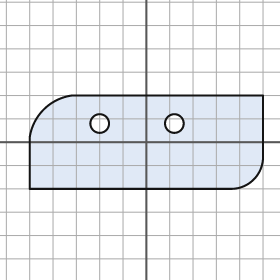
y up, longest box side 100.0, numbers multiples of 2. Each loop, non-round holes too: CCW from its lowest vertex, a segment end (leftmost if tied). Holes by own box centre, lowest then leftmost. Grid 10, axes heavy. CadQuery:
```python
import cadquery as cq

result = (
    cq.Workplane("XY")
    .moveTo(-50.0, -20.0)
    .lineTo(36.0, -20.0)
    .threePointArc((46.0, -16.0), (50.0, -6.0))
    .lineTo(50.0, 20.0)
    .lineTo(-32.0, 20.0)
    .threePointArc((-44.0, 14.0), (-50.0, 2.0))
    .close()
    .moveTo(-20.0, 8.0)
    .circle(4.0)
    .moveTo(12.0, 8.0)
    .circle(4.0)
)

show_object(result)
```